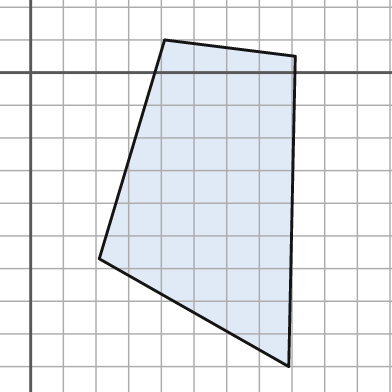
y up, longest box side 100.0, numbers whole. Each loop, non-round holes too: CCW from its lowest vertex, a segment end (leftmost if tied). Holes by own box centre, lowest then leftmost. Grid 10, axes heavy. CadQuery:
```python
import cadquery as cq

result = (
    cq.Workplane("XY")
    .moveTo(79.0, -90.0)
    .lineTo(81.0, 5.0)
    .lineTo(41.0, 10.0)
    .lineTo(21.0, -57.0)
    .close()
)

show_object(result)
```